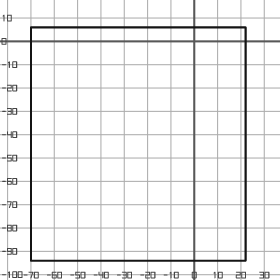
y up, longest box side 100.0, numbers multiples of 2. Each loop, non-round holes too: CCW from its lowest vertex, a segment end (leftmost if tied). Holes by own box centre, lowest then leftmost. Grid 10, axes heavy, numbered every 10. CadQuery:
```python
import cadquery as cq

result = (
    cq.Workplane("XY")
    .moveTo(-70.0, -94.0)
    .lineTo(22.0, -94.0)
    .lineTo(22.0, 6.0)
    .lineTo(-70.0, 6.0)
    .close()
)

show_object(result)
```